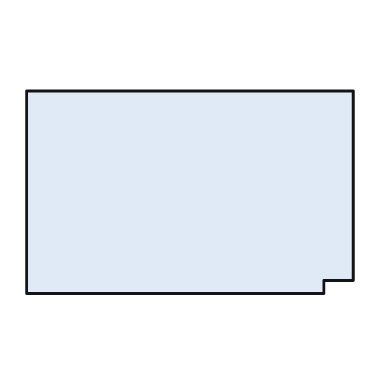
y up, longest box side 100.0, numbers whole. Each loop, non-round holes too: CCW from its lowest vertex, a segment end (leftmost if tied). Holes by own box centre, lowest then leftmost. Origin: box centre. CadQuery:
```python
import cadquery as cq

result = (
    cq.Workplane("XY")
    .moveTo(-50.0, -31.0)
    .lineTo(41.0, -31.0)
    .lineTo(41.0, -27.0)
    .lineTo(50.0, -27.0)
    .lineTo(50.0, 31.0)
    .lineTo(-50.0, 31.0)
    .close()
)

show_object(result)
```